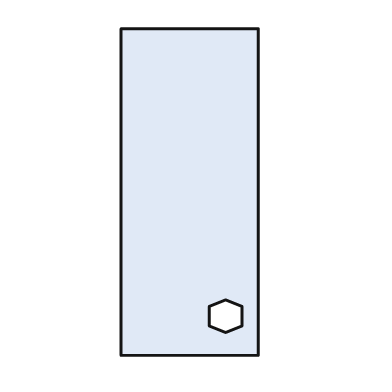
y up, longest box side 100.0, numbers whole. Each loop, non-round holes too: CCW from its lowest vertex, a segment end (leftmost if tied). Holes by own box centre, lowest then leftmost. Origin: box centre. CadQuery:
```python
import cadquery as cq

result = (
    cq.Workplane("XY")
    .moveTo(-21.0, -50.0)
    .lineTo(21.0, -50.0)
    .lineTo(21.0, 50.0)
    .lineTo(-21.0, 50.0)
    .close()
    .moveTo(11.0, -43.0)
    .lineTo(16.0, -41.0)
    .lineTo(16.0, -35.0)
    .lineTo(11.0, -33.0)
    .lineTo(6.0, -35.0)
    .lineTo(6.0, -41.0)
    .close()
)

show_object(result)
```